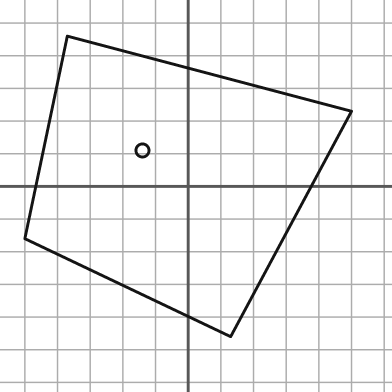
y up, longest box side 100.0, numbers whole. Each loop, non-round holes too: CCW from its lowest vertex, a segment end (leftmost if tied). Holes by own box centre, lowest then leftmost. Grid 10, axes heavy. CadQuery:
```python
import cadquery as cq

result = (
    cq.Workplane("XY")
    .moveTo(13.0, -46.0)
    .lineTo(50.0, 23.0)
    .lineTo(-37.0, 46.0)
    .lineTo(-50.0, -16.0)
    .close()
    .moveTo(-14.0, 11.0)
    .circle(2.0)
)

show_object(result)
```